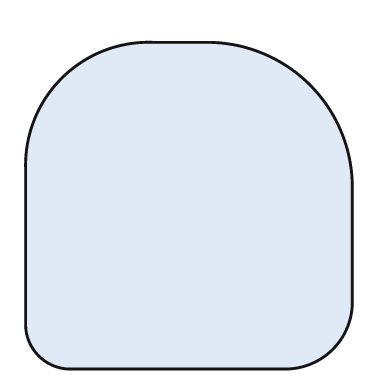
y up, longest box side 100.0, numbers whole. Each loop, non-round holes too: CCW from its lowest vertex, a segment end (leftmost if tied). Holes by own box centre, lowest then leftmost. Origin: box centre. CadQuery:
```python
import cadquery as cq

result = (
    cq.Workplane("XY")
    .moveTo(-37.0, -50.0)
    .lineTo(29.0, -50.0)
    .threePointArc((44.0, -44.0), (50.0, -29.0))
    .lineTo(50.0, 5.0)
    .threePointArc((37.0, 37.0), (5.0, 50.0))
    .lineTo(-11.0, 50.0)
    .threePointArc((-39.0, 39.0), (-50.0, 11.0))
    .lineTo(-50.0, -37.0)
    .threePointArc((-46.0, -46.0), (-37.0, -50.0))
    .close()
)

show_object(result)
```